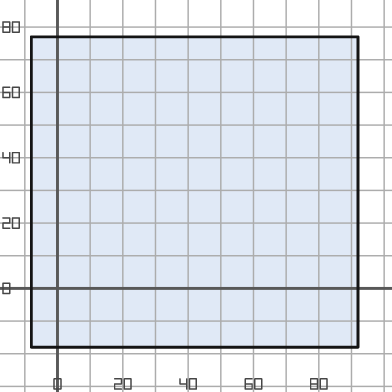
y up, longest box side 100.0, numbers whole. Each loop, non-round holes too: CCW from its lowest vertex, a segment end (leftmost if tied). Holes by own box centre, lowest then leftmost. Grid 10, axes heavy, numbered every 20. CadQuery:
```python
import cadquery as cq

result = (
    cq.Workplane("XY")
    .moveTo(-8.0, -18.0)
    .lineTo(92.0, -18.0)
    .lineTo(92.0, 77.0)
    .lineTo(-8.0, 77.0)
    .close()
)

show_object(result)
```